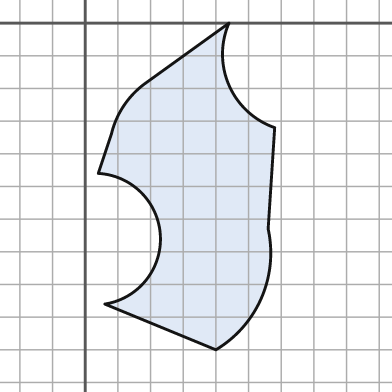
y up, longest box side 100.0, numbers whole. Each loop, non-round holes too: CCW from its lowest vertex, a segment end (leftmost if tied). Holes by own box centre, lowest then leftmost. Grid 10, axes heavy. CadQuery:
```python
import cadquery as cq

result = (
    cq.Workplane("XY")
    .moveTo(40.0, -100.0)
    .threePointArc((54.0, -84.0), (56.0, -63.0))
    .lineTo(58.0, -32.0)
    .threePointArc((44.0, -19.0), (44.0, 0.0))
    .lineTo(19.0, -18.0)
    .threePointArc((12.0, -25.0), (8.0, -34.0))
    .lineTo(4.0, -46.0)
    .threePointArc((23.0, -65.0), (6.0, -86.0))
    .close()
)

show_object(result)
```